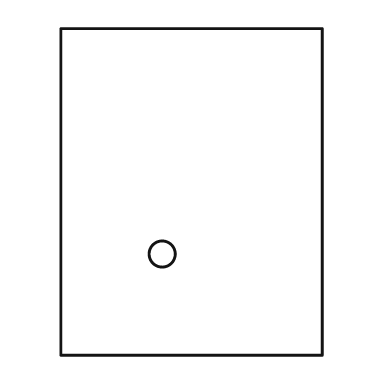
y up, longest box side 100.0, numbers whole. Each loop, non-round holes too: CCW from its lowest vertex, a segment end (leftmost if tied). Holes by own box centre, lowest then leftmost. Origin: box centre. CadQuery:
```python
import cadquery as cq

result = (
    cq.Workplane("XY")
    .moveTo(-40.0, -50.0)
    .lineTo(40.0, -50.0)
    .lineTo(40.0, 50.0)
    .lineTo(-40.0, 50.0)
    .close()
    .moveTo(-9.0, -19.0)
    .circle(4.0)
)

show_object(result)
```